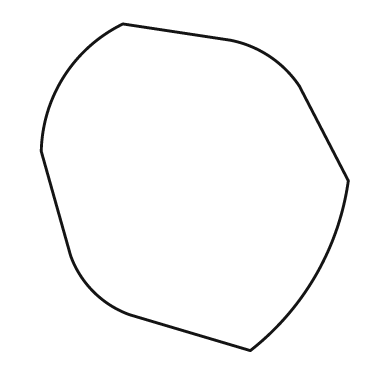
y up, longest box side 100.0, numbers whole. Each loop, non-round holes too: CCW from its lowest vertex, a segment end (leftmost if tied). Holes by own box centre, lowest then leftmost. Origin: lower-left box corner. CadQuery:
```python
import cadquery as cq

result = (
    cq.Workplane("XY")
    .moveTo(64.0, 0.0)
    .threePointArc((84.0, 23.0), (94.0, 52.0))
    .lineTo(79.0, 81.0)
    .threePointArc((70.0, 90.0), (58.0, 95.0))
    .lineTo(25.0, 100.0)
    .threePointArc((7.0, 84.0), (0.0, 61.0))
    .lineTo(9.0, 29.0)
    .threePointArc((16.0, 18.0), (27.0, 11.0))
    .close()
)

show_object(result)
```